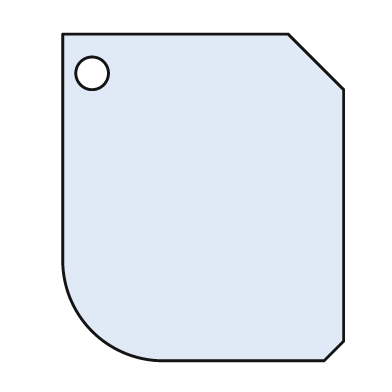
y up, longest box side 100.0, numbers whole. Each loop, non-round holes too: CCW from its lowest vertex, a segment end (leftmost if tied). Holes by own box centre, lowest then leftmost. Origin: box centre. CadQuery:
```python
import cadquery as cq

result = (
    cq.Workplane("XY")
    .moveTo(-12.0, -50.0)
    .lineTo(37.0, -50.0)
    .lineTo(43.0, -44.0)
    .lineTo(43.0, 33.0)
    .lineTo(26.0, 50.0)
    .lineTo(-43.0, 50.0)
    .lineTo(-43.0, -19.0)
    .threePointArc((-34.0, -41.0), (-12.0, -50.0))
    .close()
    .moveTo(-34.0, 38.0)
    .circle(5.0)
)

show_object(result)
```